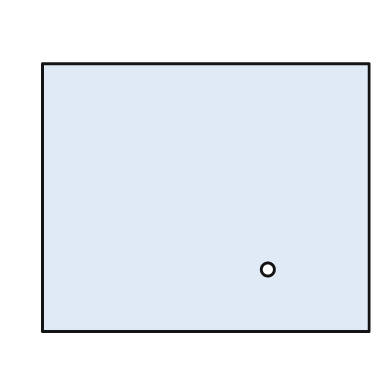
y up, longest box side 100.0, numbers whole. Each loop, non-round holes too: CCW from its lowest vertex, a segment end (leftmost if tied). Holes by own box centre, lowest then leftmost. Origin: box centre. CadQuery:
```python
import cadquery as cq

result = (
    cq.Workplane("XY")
    .moveTo(-50.0, -41.0)
    .lineTo(50.0, -41.0)
    .lineTo(50.0, 41.0)
    .lineTo(-50.0, 41.0)
    .close()
    .moveTo(19.0, -22.0)
    .circle(2.0)
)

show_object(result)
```